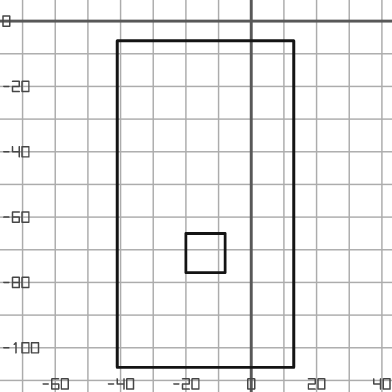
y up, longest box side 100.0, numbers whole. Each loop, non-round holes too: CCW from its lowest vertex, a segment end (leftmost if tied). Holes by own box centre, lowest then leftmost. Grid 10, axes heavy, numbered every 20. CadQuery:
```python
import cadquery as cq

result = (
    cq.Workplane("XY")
    .moveTo(-41.0, -106.0)
    .lineTo(13.0, -106.0)
    .lineTo(13.0, -6.0)
    .lineTo(-41.0, -6.0)
    .close()
    .moveTo(-20.0, -77.0)
    .lineTo(-8.0, -77.0)
    .lineTo(-8.0, -65.0)
    .lineTo(-20.0, -65.0)
    .close()
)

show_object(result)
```